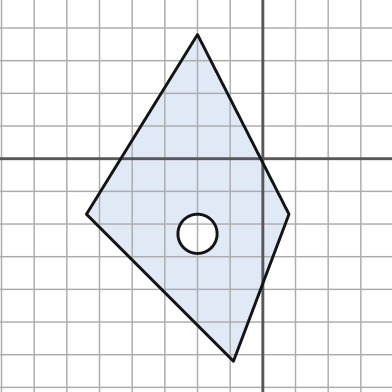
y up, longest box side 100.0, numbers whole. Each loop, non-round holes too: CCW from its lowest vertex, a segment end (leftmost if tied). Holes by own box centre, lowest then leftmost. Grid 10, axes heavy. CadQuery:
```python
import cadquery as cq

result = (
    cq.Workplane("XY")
    .moveTo(-9.0, -62.0)
    .lineTo(8.0, -17.0)
    .lineTo(-20.0, 38.0)
    .lineTo(-54.0, -17.0)
    .close()
    .moveTo(-20.0, -23.0)
    .circle(6.0)
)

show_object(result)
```